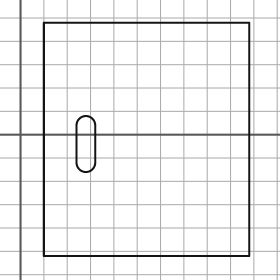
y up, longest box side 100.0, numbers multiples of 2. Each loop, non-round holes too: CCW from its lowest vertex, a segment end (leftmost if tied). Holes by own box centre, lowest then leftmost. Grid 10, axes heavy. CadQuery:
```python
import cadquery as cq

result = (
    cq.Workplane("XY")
    .moveTo(10.0, -52.0)
    .lineTo(98.0, -52.0)
    .lineTo(98.0, 48.0)
    .lineTo(10.0, 48.0)
    .close()
    .moveTo(24.0, -12.0)
    .threePointArc((28.0, -16.0), (32.0, -12.0))
    .lineTo(32.0, 4.0)
    .threePointArc((28.0, 8.0), (24.0, 4.0))
    .close()
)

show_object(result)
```